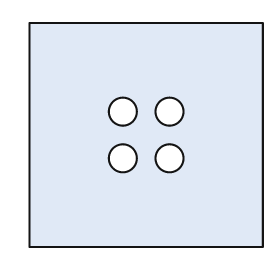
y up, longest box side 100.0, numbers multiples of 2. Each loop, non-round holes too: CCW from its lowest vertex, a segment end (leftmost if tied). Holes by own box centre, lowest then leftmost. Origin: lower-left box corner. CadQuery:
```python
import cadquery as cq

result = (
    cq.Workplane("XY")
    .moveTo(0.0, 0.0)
    .lineTo(100.0, 0.0)
    .lineTo(100.0, 96.0)
    .lineTo(0.0, 96.0)
    .close()
    .moveTo(40.0, 38.0)
    .circle(6.0)
    .moveTo(60.0, 38.0)
    .circle(6.0)
    .moveTo(40.0, 58.0)
    .circle(6.0)
    .moveTo(60.0, 58.0)
    .circle(6.0)
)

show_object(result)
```